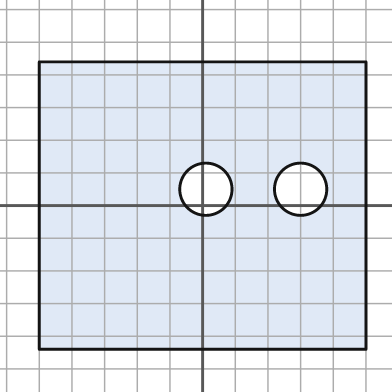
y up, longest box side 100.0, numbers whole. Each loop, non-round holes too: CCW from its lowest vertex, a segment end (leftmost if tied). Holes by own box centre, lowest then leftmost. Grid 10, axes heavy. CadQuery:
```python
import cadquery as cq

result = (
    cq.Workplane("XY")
    .moveTo(-50.0, -44.0)
    .lineTo(50.0, -44.0)
    .lineTo(50.0, 44.0)
    .lineTo(-50.0, 44.0)
    .close()
    .moveTo(1.0, 5.0)
    .circle(8.0)
    .moveTo(30.0, 5.0)
    .circle(8.0)
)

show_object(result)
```